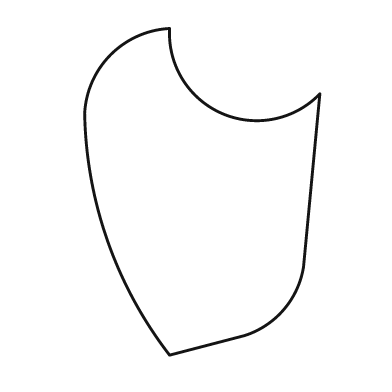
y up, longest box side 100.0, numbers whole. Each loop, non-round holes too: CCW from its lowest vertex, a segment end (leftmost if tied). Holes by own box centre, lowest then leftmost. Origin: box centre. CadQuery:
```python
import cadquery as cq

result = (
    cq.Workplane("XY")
    .moveTo(-10.0, -50.0)
    .lineTo(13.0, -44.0)
    .threePointArc((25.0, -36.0), (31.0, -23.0))
    .lineTo(36.0, 30.0)
    .threePointArc((6.0, 24.0), (-10.0, 50.0))
    .threePointArc((-28.0, 42.0), (-36.0, 24.0))
    .threePointArc((-29.0, -15.0), (-10.0, -50.0))
    .close()
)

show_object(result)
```